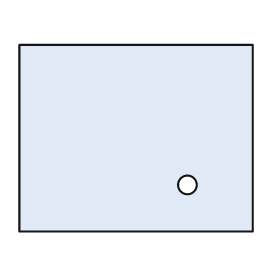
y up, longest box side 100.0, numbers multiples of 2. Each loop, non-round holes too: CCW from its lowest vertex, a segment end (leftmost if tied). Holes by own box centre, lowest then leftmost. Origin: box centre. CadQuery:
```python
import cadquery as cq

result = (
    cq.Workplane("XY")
    .moveTo(-50.0, -40.0)
    .lineTo(50.0, -40.0)
    .lineTo(50.0, 40.0)
    .lineTo(-50.0, 40.0)
    .close()
    .moveTo(22.0, -20.0)
    .circle(4.0)
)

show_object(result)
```